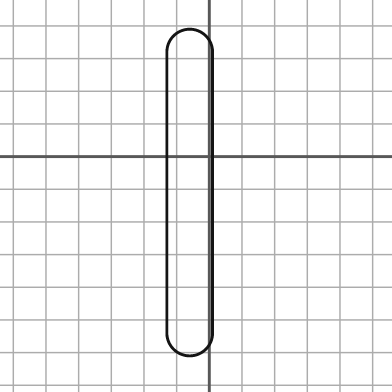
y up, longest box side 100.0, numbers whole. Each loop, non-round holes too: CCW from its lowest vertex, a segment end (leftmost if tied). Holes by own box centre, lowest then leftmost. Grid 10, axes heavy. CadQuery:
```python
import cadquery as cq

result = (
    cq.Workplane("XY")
    .moveTo(-13.0, -54.0)
    .threePointArc((-6.0, -61.0), (1.0, -54.0))
    .lineTo(1.0, 32.0)
    .threePointArc((-6.0, 39.0), (-13.0, 32.0))
    .close()
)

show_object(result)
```